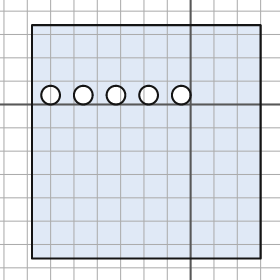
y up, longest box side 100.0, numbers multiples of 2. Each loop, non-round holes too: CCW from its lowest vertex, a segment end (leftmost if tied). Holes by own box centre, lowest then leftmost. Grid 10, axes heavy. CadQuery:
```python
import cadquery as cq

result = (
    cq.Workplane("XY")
    .moveTo(-68.0, -66.0)
    .lineTo(30.0, -66.0)
    .lineTo(30.0, 34.0)
    .lineTo(-68.0, 34.0)
    .close()
    .moveTo(-60.0, 4.0)
    .circle(4.0)
    .moveTo(-46.0, 4.0)
    .circle(4.0)
    .moveTo(-32.0, 4.0)
    .circle(4.0)
    .moveTo(-18.0, 4.0)
    .circle(4.0)
    .moveTo(-4.0, 4.0)
    .circle(4.0)
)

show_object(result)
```